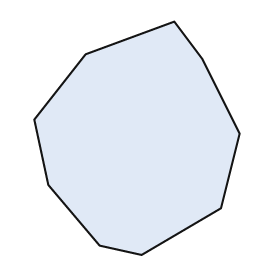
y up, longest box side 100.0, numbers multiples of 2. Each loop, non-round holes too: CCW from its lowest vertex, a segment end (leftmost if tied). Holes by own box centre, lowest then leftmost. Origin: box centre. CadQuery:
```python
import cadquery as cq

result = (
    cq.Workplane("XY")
    .moveTo(2.0, -50.0)
    .lineTo(36.0, -30.0)
    .lineTo(44.0, 2.0)
    .lineTo(28.0, 34.0)
    .lineTo(16.0, 50.0)
    .lineTo(-22.0, 36.0)
    .lineTo(-44.0, 8.0)
    .lineTo(-38.0, -20.0)
    .lineTo(-16.0, -46.0)
    .close()
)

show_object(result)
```